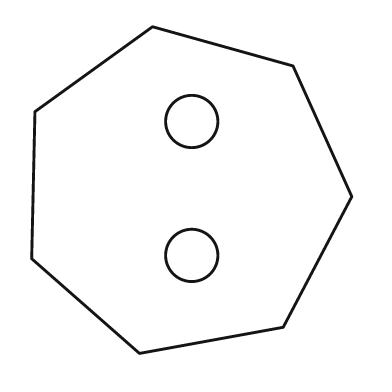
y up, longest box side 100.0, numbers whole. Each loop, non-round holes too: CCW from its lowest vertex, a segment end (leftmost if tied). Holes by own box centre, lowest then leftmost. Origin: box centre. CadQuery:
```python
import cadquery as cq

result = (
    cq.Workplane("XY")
    .moveTo(-16.0, -50.0)
    .lineTo(28.0, -42.0)
    .lineTo(49.0, -2.0)
    .lineTo(31.0, 38.0)
    .lineTo(-12.0, 50.0)
    .lineTo(-48.0, 24.0)
    .lineTo(-49.0, -21.0)
    .close()
    .moveTo(0.0, -20.0)
    .circle(8.0)
    .moveTo(0.0, 21.0)
    .circle(8.0)
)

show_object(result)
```